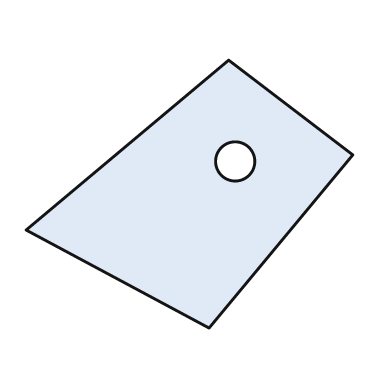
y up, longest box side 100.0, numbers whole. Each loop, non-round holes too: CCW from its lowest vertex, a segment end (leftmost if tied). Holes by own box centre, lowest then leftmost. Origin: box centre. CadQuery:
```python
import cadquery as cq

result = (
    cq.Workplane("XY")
    .moveTo(6.0, -41.0)
    .lineTo(50.0, 12.0)
    .lineTo(12.0, 41.0)
    .lineTo(-50.0, -11.0)
    .close()
    .moveTo(14.0, 10.0)
    .circle(6.0)
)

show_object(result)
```